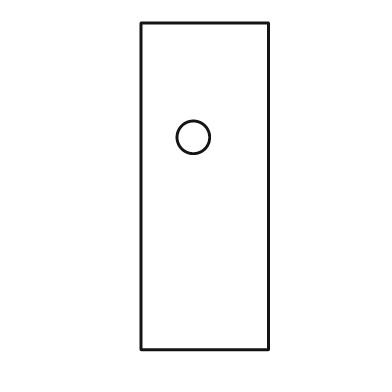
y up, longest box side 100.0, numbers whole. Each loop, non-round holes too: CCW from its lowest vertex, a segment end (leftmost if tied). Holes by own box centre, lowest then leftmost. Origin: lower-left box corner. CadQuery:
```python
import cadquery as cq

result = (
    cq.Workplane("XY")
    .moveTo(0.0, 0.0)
    .lineTo(39.0, 0.0)
    .lineTo(39.0, 100.0)
    .lineTo(0.0, 100.0)
    .close()
    .moveTo(16.0, 65.0)
    .circle(5.0)
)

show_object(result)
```